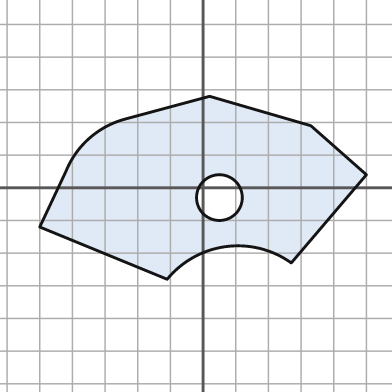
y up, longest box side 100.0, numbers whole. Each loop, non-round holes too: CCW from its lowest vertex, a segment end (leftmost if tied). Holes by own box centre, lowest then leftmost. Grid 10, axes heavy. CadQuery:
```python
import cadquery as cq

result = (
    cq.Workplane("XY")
    .moveTo(-11.0, -28.0)
    .threePointArc((7.0, -18.0), (27.0, -23.0))
    .lineTo(50.0, 4.0)
    .lineTo(33.0, 19.0)
    .lineTo(2.0, 28.0)
    .lineTo(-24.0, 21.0)
    .threePointArc((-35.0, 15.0), (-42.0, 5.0))
    .lineTo(-50.0, -12.0)
    .close()
    .moveTo(5.0, -3.0)
    .circle(7.0)
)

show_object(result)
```